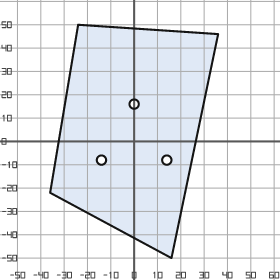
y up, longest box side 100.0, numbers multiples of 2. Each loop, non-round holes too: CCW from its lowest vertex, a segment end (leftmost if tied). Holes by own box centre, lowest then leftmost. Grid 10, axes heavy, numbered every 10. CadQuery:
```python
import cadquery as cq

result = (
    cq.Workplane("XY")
    .moveTo(16.0, -50.0)
    .lineTo(36.0, 46.0)
    .lineTo(-24.0, 50.0)
    .lineTo(-36.0, -22.0)
    .close()
    .moveTo(-14.0, -8.0)
    .circle(2.0)
    .moveTo(14.0, -8.0)
    .circle(2.0)
    .moveTo(0.0, 16.0)
    .circle(2.0)
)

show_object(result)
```